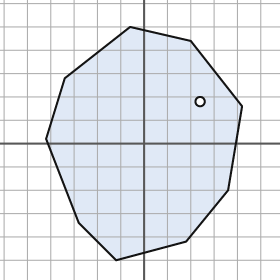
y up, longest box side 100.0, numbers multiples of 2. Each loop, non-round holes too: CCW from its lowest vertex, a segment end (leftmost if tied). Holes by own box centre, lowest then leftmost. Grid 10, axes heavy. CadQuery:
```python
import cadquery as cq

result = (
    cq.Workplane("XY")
    .moveTo(-12.0, -50.0)
    .lineTo(18.0, -42.0)
    .lineTo(36.0, -20.0)
    .lineTo(42.0, 16.0)
    .lineTo(20.0, 44.0)
    .lineTo(-6.0, 50.0)
    .lineTo(-34.0, 28.0)
    .lineTo(-42.0, 2.0)
    .lineTo(-28.0, -34.0)
    .close()
    .moveTo(24.0, 18.0)
    .circle(2.0)
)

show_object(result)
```